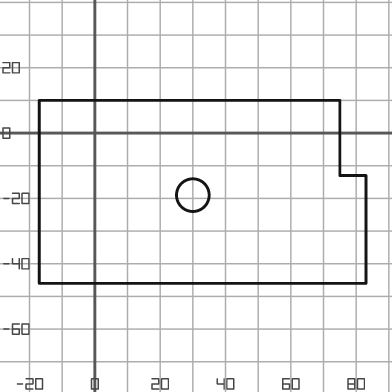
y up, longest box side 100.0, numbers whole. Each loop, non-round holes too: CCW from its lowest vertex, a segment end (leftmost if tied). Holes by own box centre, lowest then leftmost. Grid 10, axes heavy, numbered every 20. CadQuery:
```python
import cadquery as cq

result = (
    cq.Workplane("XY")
    .moveTo(-17.0, -46.0)
    .lineTo(83.0, -46.0)
    .lineTo(83.0, -13.0)
    .lineTo(75.0, -13.0)
    .lineTo(75.0, 10.0)
    .lineTo(-17.0, 10.0)
    .close()
    .moveTo(30.0, -19.0)
    .circle(5.0)
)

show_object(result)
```